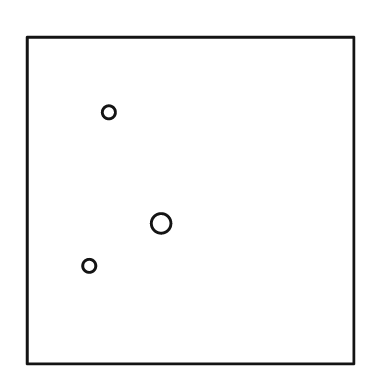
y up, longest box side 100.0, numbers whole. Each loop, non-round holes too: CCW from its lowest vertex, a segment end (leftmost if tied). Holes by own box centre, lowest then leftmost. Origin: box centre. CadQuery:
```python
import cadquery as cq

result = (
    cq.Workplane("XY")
    .moveTo(-50.0, -50.0)
    .lineTo(50.0, -50.0)
    .lineTo(50.0, 50.0)
    .lineTo(-50.0, 50.0)
    .close()
    .moveTo(-31.0, -20.0)
    .circle(2.0)
    .moveTo(-9.0, -7.0)
    .circle(3.0)
    .moveTo(-25.0, 27.0)
    .circle(2.0)
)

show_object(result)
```